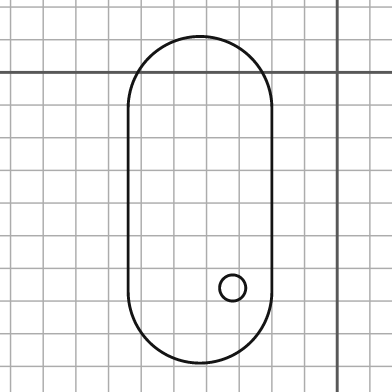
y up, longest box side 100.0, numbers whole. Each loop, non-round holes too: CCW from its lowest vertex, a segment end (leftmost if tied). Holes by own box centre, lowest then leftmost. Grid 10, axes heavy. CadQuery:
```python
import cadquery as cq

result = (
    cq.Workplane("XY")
    .moveTo(-64.0, -67.0)
    .threePointArc((-42.0, -89.0), (-20.0, -67.0))
    .lineTo(-20.0, -11.0)
    .threePointArc((-42.0, 11.0), (-64.0, -11.0))
    .close()
    .moveTo(-32.0, -66.0)
    .circle(4.0)
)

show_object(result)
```